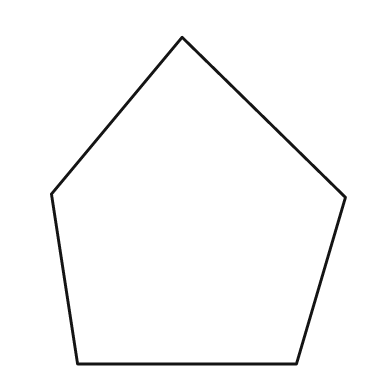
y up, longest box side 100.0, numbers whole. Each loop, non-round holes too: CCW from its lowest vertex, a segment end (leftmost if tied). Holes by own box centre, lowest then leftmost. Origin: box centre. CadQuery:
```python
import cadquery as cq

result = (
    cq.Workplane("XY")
    .moveTo(-37.0, -50.0)
    .lineTo(30.0, -50.0)
    .lineTo(45.0, 1.0)
    .lineTo(-5.0, 50.0)
    .lineTo(-45.0, 2.0)
    .close()
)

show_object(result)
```